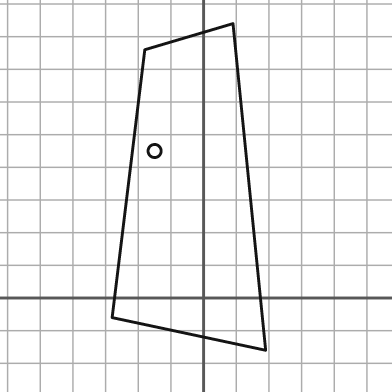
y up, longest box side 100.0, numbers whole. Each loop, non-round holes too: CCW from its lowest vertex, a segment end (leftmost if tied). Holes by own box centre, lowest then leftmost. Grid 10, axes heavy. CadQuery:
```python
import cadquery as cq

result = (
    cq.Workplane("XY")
    .moveTo(19.0, -16.0)
    .lineTo(9.0, 84.0)
    .lineTo(-18.0, 76.0)
    .lineTo(-28.0, -6.0)
    .close()
    .moveTo(-15.0, 45.0)
    .circle(2.0)
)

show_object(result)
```